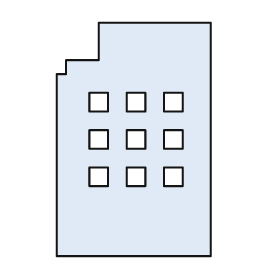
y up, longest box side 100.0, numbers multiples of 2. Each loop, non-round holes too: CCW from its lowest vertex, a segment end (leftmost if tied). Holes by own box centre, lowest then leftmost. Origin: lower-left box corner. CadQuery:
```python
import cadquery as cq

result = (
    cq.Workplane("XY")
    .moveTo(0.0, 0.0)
    .lineTo(66.0, 0.0)
    .lineTo(66.0, 100.0)
    .lineTo(18.0, 100.0)
    .lineTo(18.0, 84.0)
    .lineTo(4.0, 84.0)
    .lineTo(4.0, 78.0)
    .lineTo(0.0, 78.0)
    .close()
    .moveTo(14.0, 30.0)
    .lineTo(22.0, 30.0)
    .lineTo(22.0, 38.0)
    .lineTo(14.0, 38.0)
    .close()
    .moveTo(30.0, 30.0)
    .lineTo(38.0, 30.0)
    .lineTo(38.0, 38.0)
    .lineTo(30.0, 38.0)
    .close()
    .moveTo(46.0, 30.0)
    .lineTo(54.0, 30.0)
    .lineTo(54.0, 38.0)
    .lineTo(46.0, 38.0)
    .close()
    .moveTo(14.0, 46.0)
    .lineTo(22.0, 46.0)
    .lineTo(22.0, 54.0)
    .lineTo(14.0, 54.0)
    .close()
    .moveTo(30.0, 46.0)
    .lineTo(38.0, 46.0)
    .lineTo(38.0, 54.0)
    .lineTo(30.0, 54.0)
    .close()
    .moveTo(46.0, 46.0)
    .lineTo(54.0, 46.0)
    .lineTo(54.0, 54.0)
    .lineTo(46.0, 54.0)
    .close()
    .moveTo(14.0, 62.0)
    .lineTo(22.0, 62.0)
    .lineTo(22.0, 70.0)
    .lineTo(14.0, 70.0)
    .close()
    .moveTo(30.0, 62.0)
    .lineTo(38.0, 62.0)
    .lineTo(38.0, 70.0)
    .lineTo(30.0, 70.0)
    .close()
    .moveTo(46.0, 62.0)
    .lineTo(54.0, 62.0)
    .lineTo(54.0, 70.0)
    .lineTo(46.0, 70.0)
    .close()
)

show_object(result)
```